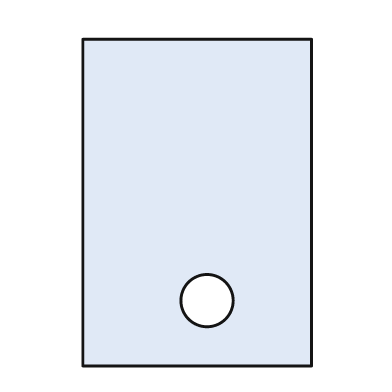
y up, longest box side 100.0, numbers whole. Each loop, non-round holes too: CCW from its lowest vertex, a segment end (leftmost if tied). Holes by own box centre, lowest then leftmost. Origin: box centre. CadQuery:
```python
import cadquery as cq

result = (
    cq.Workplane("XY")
    .moveTo(-35.0, -50.0)
    .lineTo(35.0, -50.0)
    .lineTo(35.0, 50.0)
    .lineTo(-35.0, 50.0)
    .close()
    .moveTo(3.0, -30.0)
    .circle(8.0)
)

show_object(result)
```